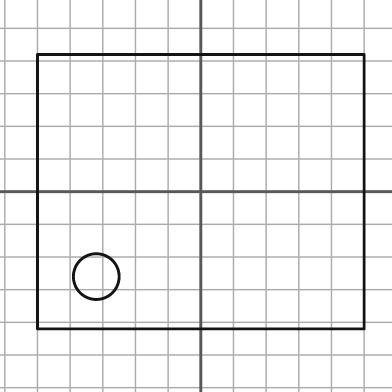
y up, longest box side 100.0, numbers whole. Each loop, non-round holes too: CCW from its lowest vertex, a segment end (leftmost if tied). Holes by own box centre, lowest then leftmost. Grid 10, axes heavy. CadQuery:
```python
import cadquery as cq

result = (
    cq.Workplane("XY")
    .moveTo(-50.0, -42.0)
    .lineTo(50.0, -42.0)
    .lineTo(50.0, 42.0)
    .lineTo(-50.0, 42.0)
    .close()
    .moveTo(-32.0, -26.0)
    .circle(7.0)
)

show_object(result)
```